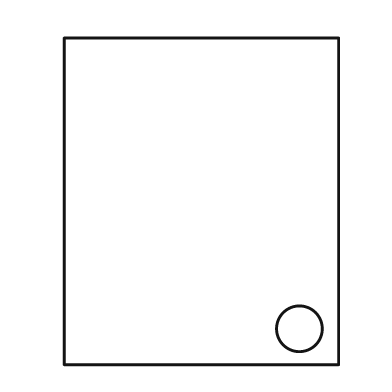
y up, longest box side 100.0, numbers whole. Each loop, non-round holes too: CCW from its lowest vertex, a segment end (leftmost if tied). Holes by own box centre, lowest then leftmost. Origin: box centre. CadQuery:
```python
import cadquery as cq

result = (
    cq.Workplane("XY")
    .moveTo(-42.0, -50.0)
    .lineTo(42.0, -50.0)
    .lineTo(42.0, 50.0)
    .lineTo(-42.0, 50.0)
    .close()
    .moveTo(30.0, -39.0)
    .circle(7.0)
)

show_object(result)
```